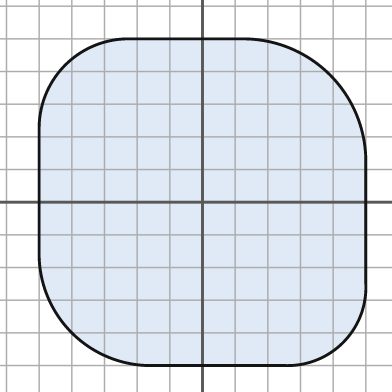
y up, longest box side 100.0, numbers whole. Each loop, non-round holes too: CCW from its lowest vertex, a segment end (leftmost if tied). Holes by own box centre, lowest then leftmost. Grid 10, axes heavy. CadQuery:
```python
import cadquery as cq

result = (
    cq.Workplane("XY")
    .moveTo(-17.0, -50.0)
    .lineTo(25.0, -50.0)
    .threePointArc((43.0, -43.0), (50.0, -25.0))
    .lineTo(50.0, 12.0)
    .threePointArc((39.0, 39.0), (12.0, 50.0))
    .lineTo(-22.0, 50.0)
    .threePointArc((-42.0, 42.0), (-50.0, 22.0))
    .lineTo(-50.0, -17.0)
    .threePointArc((-40.0, -40.0), (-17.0, -50.0))
    .close()
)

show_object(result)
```